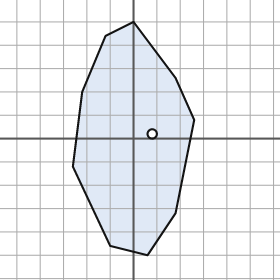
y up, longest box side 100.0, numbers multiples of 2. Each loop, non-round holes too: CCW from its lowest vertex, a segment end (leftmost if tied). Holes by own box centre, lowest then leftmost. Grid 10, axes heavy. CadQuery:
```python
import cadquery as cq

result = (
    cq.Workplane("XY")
    .moveTo(6.0, -50.0)
    .lineTo(18.0, -32.0)
    .lineTo(26.0, 8.0)
    .lineTo(18.0, 26.0)
    .lineTo(0.0, 50.0)
    .lineTo(-12.0, 44.0)
    .lineTo(-22.0, 20.0)
    .lineTo(-26.0, -12.0)
    .lineTo(-10.0, -46.0)
    .close()
    .moveTo(8.0, 2.0)
    .circle(2.0)
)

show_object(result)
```